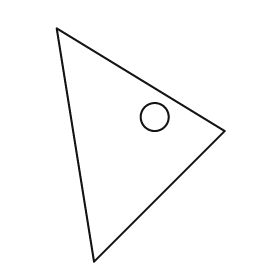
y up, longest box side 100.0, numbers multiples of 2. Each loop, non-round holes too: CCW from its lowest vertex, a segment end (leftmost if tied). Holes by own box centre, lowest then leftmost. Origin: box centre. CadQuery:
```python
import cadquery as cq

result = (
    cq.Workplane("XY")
    .moveTo(-20.0, -50.0)
    .lineTo(36.0, 6.0)
    .lineTo(-36.0, 50.0)
    .close()
    .moveTo(6.0, 12.0)
    .circle(6.0)
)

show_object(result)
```